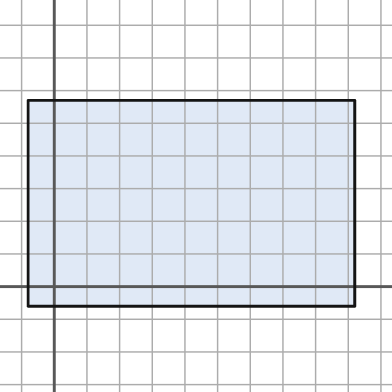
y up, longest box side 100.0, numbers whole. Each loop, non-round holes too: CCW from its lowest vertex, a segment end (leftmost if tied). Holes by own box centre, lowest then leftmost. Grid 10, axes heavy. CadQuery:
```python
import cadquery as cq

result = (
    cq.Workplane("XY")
    .moveTo(-8.0, -6.0)
    .lineTo(92.0, -6.0)
    .lineTo(92.0, 57.0)
    .lineTo(-8.0, 57.0)
    .close()
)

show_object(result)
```